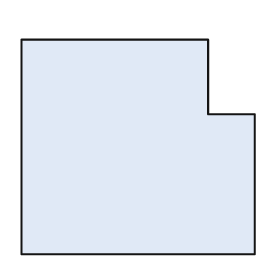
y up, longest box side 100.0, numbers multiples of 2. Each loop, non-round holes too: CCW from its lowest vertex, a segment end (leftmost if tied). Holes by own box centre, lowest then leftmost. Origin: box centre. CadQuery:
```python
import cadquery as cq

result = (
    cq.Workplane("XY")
    .moveTo(-50.0, -46.0)
    .lineTo(50.0, -46.0)
    .lineTo(50.0, 14.0)
    .lineTo(30.0, 14.0)
    .lineTo(30.0, 46.0)
    .lineTo(-50.0, 46.0)
    .close()
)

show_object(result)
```